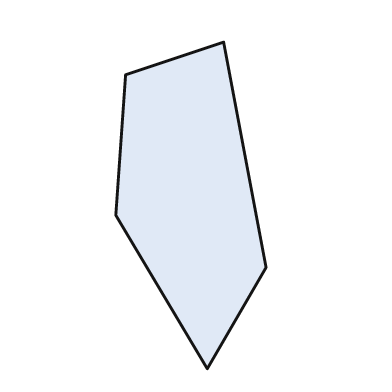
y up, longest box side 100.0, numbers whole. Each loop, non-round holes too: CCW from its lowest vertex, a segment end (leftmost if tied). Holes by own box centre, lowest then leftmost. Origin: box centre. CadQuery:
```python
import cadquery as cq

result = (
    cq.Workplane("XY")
    .moveTo(5.0, -50.0)
    .lineTo(23.0, -19.0)
    .lineTo(10.0, 50.0)
    .lineTo(-20.0, 40.0)
    .lineTo(-23.0, -3.0)
    .close()
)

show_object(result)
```